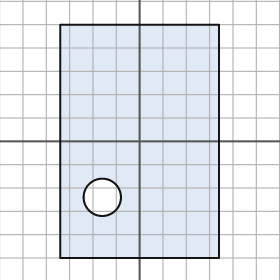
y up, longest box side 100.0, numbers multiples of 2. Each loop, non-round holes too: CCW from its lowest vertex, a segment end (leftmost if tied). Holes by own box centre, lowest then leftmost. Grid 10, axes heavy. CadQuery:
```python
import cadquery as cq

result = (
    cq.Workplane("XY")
    .moveTo(-34.0, -50.0)
    .lineTo(34.0, -50.0)
    .lineTo(34.0, 50.0)
    .lineTo(-34.0, 50.0)
    .close()
    .moveTo(-16.0, -24.0)
    .circle(8.0)
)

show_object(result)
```